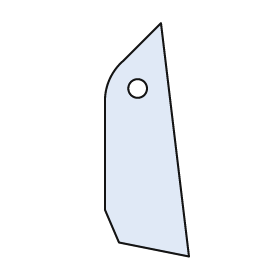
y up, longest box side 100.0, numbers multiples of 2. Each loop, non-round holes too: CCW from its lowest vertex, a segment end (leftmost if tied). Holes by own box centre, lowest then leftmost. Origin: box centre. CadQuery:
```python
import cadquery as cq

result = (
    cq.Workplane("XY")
    .moveTo(18.0, -50.0)
    .lineTo(6.0, 50.0)
    .lineTo(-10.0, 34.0)
    .threePointArc((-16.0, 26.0), (-18.0, 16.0))
    .lineTo(-18.0, -30.0)
    .lineTo(-12.0, -44.0)
    .close()
    .moveTo(-4.0, 22.0)
    .circle(4.0)
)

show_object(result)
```